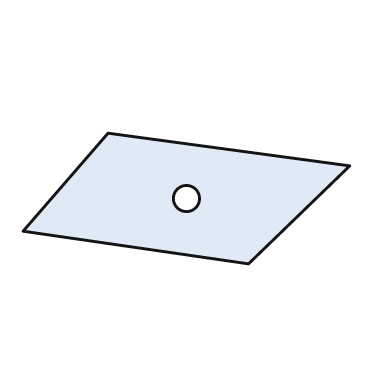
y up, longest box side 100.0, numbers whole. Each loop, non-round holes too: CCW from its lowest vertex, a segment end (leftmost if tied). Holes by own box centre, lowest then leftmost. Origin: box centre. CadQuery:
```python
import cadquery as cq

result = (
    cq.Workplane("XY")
    .moveTo(19.0, -20.0)
    .lineTo(50.0, 10.0)
    .lineTo(-24.0, 20.0)
    .lineTo(-50.0, -10.0)
    .close()
    .moveTo(0.0, 0.0)
    .circle(4.0)
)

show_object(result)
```